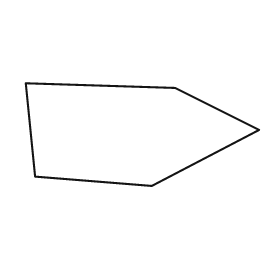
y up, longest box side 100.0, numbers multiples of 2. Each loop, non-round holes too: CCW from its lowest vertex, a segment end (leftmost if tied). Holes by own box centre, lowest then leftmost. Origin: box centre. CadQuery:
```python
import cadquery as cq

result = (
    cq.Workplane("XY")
    .moveTo(4.0, -22.0)
    .lineTo(50.0, 2.0)
    .lineTo(14.0, 20.0)
    .lineTo(-50.0, 22.0)
    .lineTo(-46.0, -18.0)
    .close()
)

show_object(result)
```